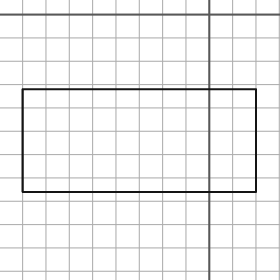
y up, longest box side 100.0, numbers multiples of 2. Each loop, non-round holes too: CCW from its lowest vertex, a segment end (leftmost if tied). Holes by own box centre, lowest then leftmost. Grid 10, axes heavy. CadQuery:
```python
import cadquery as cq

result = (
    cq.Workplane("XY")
    .moveTo(-80.0, -76.0)
    .lineTo(20.0, -76.0)
    .lineTo(20.0, -32.0)
    .lineTo(-80.0, -32.0)
    .close()
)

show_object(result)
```